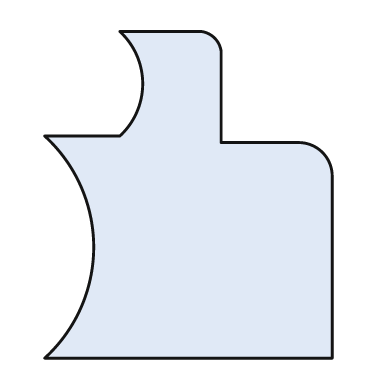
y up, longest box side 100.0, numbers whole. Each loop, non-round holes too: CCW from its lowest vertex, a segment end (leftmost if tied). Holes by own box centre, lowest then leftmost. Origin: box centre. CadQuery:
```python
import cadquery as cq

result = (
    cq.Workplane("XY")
    .moveTo(-44.0, -50.0)
    .lineTo(44.0, -50.0)
    .lineTo(44.0, 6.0)
    .threePointArc((41.0, 13.0), (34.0, 16.0))
    .lineTo(10.0, 16.0)
    .lineTo(10.0, 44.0)
    .threePointArc((8.0, 48.0), (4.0, 50.0))
    .lineTo(-21.0, 50.0)
    .threePointArc((-14.0, 34.0), (-21.0, 18.0))
    .lineTo(-44.0, 18.0)
    .threePointArc((-29.0, -16.0), (-44.0, -50.0))
    .close()
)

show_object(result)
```